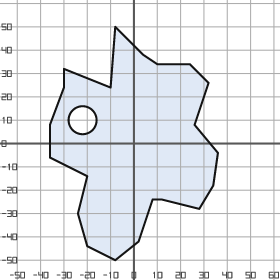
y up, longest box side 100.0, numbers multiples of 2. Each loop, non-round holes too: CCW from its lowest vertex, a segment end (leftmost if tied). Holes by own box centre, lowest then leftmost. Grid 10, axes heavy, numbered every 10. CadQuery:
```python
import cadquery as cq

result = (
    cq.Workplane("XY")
    .moveTo(-8.0, -50.0)
    .lineTo(2.0, -42.0)
    .lineTo(8.0, -24.0)
    .lineTo(12.0, -24.0)
    .lineTo(28.0, -28.0)
    .lineTo(34.0, -18.0)
    .lineTo(36.0, -4.0)
    .lineTo(26.0, 8.0)
    .lineTo(32.0, 26.0)
    .lineTo(24.0, 34.0)
    .lineTo(10.0, 34.0)
    .lineTo(4.0, 38.0)
    .lineTo(-8.0, 50.0)
    .lineTo(-10.0, 24.0)
    .lineTo(-30.0, 32.0)
    .lineTo(-30.0, 24.0)
    .lineTo(-36.0, 8.0)
    .lineTo(-36.0, -6.0)
    .lineTo(-20.0, -14.0)
    .lineTo(-24.0, -30.0)
    .lineTo(-20.0, -44.0)
    .close()
    .moveTo(-22.0, 10.0)
    .circle(6.0)
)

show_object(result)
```